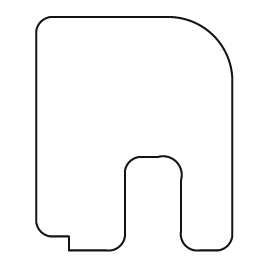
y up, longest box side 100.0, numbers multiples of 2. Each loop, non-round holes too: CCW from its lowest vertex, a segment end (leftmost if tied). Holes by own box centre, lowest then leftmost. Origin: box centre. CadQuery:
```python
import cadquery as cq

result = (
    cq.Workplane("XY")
    .moveTo(-28.0, -50.0)
    .lineTo(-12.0, -50.0)
    .threePointArc((-6.0, -48.0), (-4.0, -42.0))
    .lineTo(-4.0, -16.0)
    .threePointArc((-2.0, -12.0), (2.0, -10.0))
    .lineTo(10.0, -10.0)
    .threePointArc((18.0, -12.0), (20.0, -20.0))
    .lineTo(20.0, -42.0)
    .threePointArc((22.0, -48.0), (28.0, -50.0))
    .lineTo(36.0, -50.0)
    .threePointArc((40.0, -48.0), (42.0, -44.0))
    .lineTo(42.0, 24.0)
    .threePointArc((34.0, 42.0), (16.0, 50.0))
    .lineTo(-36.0, 50.0)
    .threePointArc((-40.0, 48.0), (-42.0, 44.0))
    .lineTo(-42.0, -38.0)
    .threePointArc((-40.0, -42.0), (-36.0, -44.0))
    .lineTo(-28.0, -44.0)
    .close()
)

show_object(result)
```